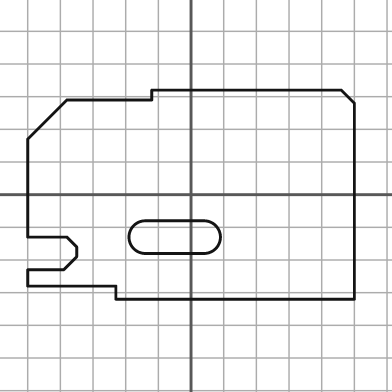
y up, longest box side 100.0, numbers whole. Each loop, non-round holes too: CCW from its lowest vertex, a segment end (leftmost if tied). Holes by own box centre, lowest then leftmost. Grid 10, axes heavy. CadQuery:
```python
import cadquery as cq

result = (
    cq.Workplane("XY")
    .moveTo(-23.0, -32.0)
    .lineTo(50.0, -32.0)
    .lineTo(50.0, 28.0)
    .lineTo(46.0, 32.0)
    .lineTo(-12.0, 32.0)
    .lineTo(-12.0, 29.0)
    .lineTo(-38.0, 29.0)
    .lineTo(-50.0, 17.0)
    .lineTo(-50.0, -13.0)
    .lineTo(-38.0, -13.0)
    .lineTo(-35.0, -16.0)
    .lineTo(-35.0, -19.0)
    .lineTo(-39.0, -23.0)
    .lineTo(-50.0, -23.0)
    .lineTo(-50.0, -28.0)
    .lineTo(-23.0, -28.0)
    .close()
    .moveTo(-14.0, -18.0)
    .lineTo(4.0, -18.0)
    .threePointArc((9.0, -13.0), (4.0, -8.0))
    .lineTo(-14.0, -8.0)
    .threePointArc((-19.0, -13.0), (-14.0, -18.0))
    .close()
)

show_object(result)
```